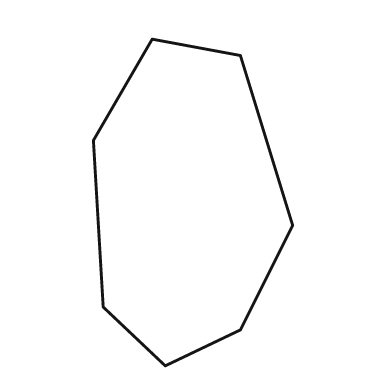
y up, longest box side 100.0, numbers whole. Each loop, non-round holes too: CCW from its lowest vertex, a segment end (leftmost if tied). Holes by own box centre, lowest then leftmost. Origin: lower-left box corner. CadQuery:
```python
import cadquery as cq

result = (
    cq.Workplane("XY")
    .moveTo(22.0, 0.0)
    .lineTo(45.0, 11.0)
    .lineTo(61.0, 43.0)
    .lineTo(45.0, 95.0)
    .lineTo(18.0, 100.0)
    .lineTo(0.0, 69.0)
    .lineTo(3.0, 18.0)
    .close()
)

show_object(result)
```